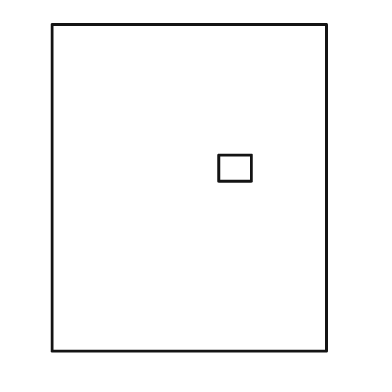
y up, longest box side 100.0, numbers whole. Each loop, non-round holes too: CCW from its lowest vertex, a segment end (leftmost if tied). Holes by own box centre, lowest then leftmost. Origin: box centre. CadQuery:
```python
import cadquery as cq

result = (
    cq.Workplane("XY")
    .moveTo(-42.0, -50.0)
    .lineTo(42.0, -50.0)
    .lineTo(42.0, 50.0)
    .lineTo(-42.0, 50.0)
    .close()
    .moveTo(9.0, 2.0)
    .lineTo(19.0, 2.0)
    .lineTo(19.0, 10.0)
    .lineTo(9.0, 10.0)
    .close()
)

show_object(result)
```